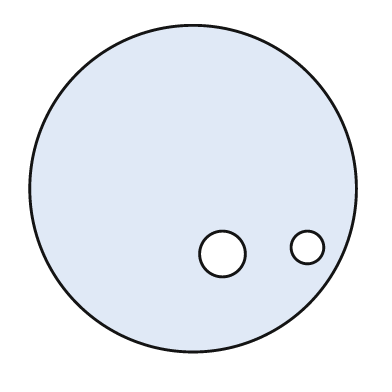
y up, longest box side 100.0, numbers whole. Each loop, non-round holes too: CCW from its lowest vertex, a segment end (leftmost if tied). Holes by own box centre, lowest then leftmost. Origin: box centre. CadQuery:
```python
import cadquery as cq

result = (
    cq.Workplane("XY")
    .moveTo(0.0, 0.0)
    .circle(50.0)
    .moveTo(9.0, -20.0)
    .circle(7.0)
    .moveTo(35.0, -18.0)
    .circle(5.0)
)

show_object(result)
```